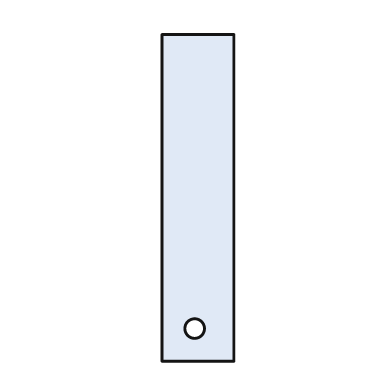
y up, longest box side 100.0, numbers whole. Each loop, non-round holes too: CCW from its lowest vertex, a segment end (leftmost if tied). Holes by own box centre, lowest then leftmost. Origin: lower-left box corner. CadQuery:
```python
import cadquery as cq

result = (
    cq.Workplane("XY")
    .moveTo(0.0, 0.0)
    .lineTo(22.0, 0.0)
    .lineTo(22.0, 100.0)
    .lineTo(0.0, 100.0)
    .close()
    .moveTo(10.0, 10.0)
    .circle(3.0)
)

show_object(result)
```